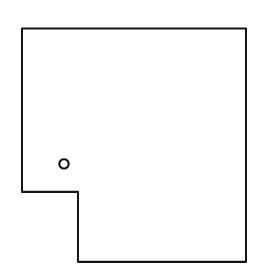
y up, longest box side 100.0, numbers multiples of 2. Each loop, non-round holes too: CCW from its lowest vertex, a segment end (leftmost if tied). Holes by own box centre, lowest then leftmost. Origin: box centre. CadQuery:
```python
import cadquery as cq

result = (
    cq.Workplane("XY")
    .moveTo(-24.0, -50.0)
    .lineTo(48.0, -50.0)
    .lineTo(48.0, 50.0)
    .lineTo(-48.0, 50.0)
    .lineTo(-48.0, -20.0)
    .lineTo(-24.0, -20.0)
    .close()
    .moveTo(-30.0, -8.0)
    .circle(2.0)
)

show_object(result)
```